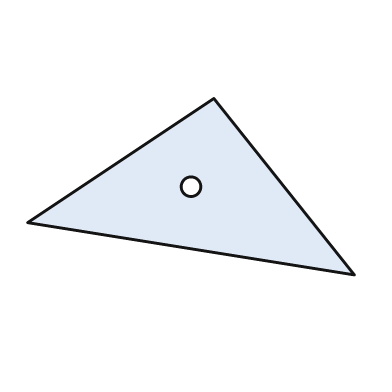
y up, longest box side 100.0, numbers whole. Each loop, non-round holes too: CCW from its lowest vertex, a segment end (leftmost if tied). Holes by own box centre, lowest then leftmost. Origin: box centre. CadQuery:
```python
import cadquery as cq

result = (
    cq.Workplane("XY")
    .moveTo(50.0, -27.0)
    .lineTo(7.0, 27.0)
    .lineTo(-50.0, -11.0)
    .close()
    .moveTo(0.0, 0.0)
    .circle(3.0)
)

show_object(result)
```